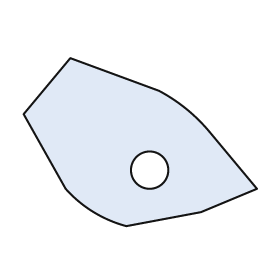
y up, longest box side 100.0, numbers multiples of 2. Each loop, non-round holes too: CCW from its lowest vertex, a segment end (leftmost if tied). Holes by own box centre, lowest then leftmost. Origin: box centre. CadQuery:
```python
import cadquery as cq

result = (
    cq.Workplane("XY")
    .moveTo(-6.0, -36.0)
    .lineTo(26.0, -30.0)
    .lineTo(50.0, -20.0)
    .lineTo(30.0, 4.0)
    .threePointArc((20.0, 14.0), (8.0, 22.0))
    .lineTo(-30.0, 36.0)
    .lineTo(-50.0, 12.0)
    .lineTo(-32.0, -20.0)
    .threePointArc((-20.0, -30.0), (-6.0, -36.0))
    .close()
    .moveTo(4.0, -12.0)
    .circle(8.0)
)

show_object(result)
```